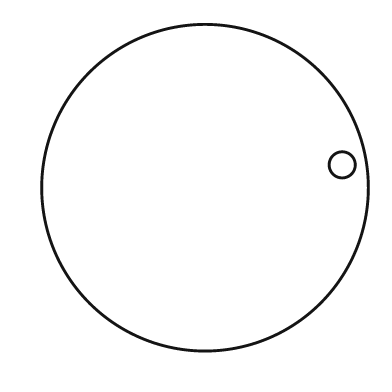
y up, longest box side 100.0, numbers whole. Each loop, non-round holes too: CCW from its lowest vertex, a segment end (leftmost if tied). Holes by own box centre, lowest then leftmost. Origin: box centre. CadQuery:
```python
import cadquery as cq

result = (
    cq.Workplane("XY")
    .moveTo(0.0, 0.0)
    .circle(50.0)
    .moveTo(42.0, 7.0)
    .circle(4.0)
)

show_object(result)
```